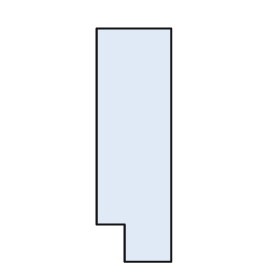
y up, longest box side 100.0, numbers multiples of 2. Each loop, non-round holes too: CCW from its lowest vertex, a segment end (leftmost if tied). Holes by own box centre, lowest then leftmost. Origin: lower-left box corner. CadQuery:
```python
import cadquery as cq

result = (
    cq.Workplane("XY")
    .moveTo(12.0, 0.0)
    .lineTo(32.0, 0.0)
    .lineTo(32.0, 100.0)
    .lineTo(0.0, 100.0)
    .lineTo(0.0, 16.0)
    .lineTo(12.0, 16.0)
    .close()
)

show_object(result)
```